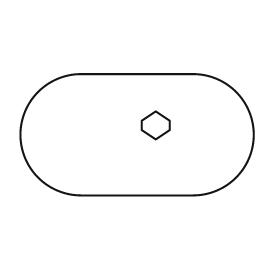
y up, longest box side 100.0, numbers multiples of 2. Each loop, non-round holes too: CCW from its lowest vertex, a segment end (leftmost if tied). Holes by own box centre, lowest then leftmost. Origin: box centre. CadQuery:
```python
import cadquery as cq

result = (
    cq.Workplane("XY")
    .moveTo(-24.0, -26.0)
    .lineTo(24.0, -26.0)
    .threePointArc((50.0, 0.0), (24.0, 26.0))
    .lineTo(-24.0, 26.0)
    .threePointArc((-50.0, 0.0), (-24.0, -26.0))
    .close()
    .moveTo(8.0, -2.0)
    .lineTo(14.0, 2.0)
    .lineTo(14.0, 6.0)
    .lineTo(8.0, 10.0)
    .lineTo(2.0, 6.0)
    .lineTo(2.0, 2.0)
    .close()
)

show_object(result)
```